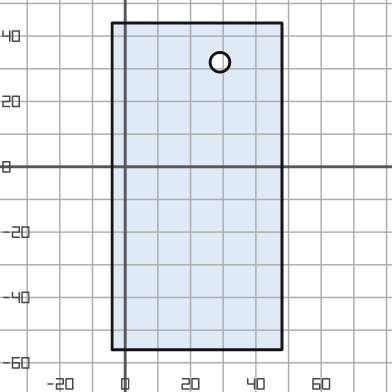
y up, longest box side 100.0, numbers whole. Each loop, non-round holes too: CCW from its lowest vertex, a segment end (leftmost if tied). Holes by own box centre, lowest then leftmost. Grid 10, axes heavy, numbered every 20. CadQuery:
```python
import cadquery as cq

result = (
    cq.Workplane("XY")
    .moveTo(-4.0, -56.0)
    .lineTo(48.0, -56.0)
    .lineTo(48.0, 44.0)
    .lineTo(-4.0, 44.0)
    .close()
    .moveTo(29.0, 32.0)
    .circle(3.0)
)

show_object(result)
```